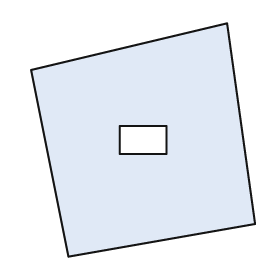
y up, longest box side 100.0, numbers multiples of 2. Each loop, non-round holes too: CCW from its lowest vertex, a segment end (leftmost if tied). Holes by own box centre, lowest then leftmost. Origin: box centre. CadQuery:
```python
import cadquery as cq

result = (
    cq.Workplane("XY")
    .moveTo(-32.0, -50.0)
    .lineTo(48.0, -36.0)
    .lineTo(36.0, 50.0)
    .lineTo(-48.0, 30.0)
    .close()
    .moveTo(-10.0, -6.0)
    .lineTo(10.0, -6.0)
    .lineTo(10.0, 6.0)
    .lineTo(-10.0, 6.0)
    .close()
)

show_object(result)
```